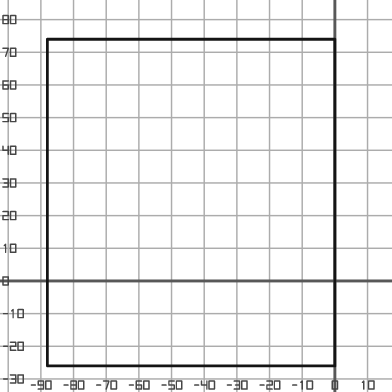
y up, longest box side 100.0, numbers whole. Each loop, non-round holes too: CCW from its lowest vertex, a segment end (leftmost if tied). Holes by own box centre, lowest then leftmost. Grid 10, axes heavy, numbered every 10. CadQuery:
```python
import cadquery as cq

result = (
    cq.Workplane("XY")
    .moveTo(-88.0, -26.0)
    .lineTo(0.0, -26.0)
    .lineTo(0.0, 74.0)
    .lineTo(-88.0, 74.0)
    .close()
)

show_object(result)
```